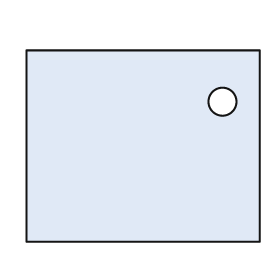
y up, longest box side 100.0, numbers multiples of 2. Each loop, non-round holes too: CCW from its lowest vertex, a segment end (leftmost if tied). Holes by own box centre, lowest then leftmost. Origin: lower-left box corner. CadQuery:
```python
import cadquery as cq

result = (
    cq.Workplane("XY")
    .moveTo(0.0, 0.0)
    .lineTo(100.0, 0.0)
    .lineTo(100.0, 82.0)
    .lineTo(0.0, 82.0)
    .close()
    .moveTo(84.0, 60.0)
    .circle(6.0)
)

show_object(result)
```